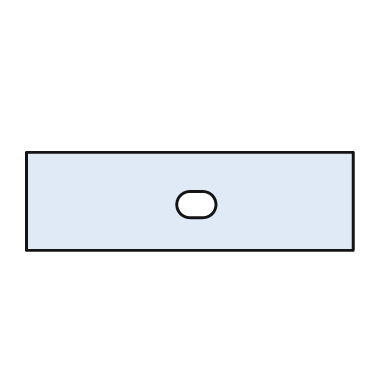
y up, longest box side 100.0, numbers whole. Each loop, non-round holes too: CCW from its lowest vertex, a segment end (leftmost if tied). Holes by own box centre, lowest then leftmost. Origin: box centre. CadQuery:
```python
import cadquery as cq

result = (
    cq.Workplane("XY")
    .moveTo(-50.0, -15.0)
    .lineTo(50.0, -15.0)
    .lineTo(50.0, 15.0)
    .lineTo(-50.0, 15.0)
    .close()
    .moveTo(0.0, -5.0)
    .lineTo(4.0, -5.0)
    .threePointArc((8.0, -1.0), (4.0, 3.0))
    .lineTo(0.0, 3.0)
    .threePointArc((-4.0, -1.0), (0.0, -5.0))
    .close()
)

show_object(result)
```